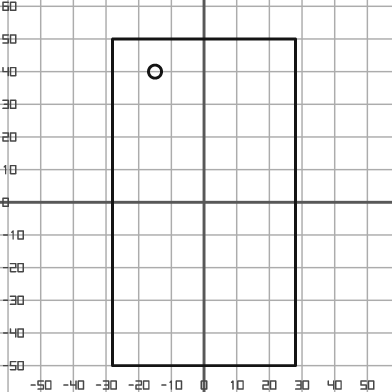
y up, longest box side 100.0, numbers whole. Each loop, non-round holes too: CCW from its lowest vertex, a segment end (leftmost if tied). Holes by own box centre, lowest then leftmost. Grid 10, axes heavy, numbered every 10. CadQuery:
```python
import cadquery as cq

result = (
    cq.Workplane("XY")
    .moveTo(-28.0, -50.0)
    .lineTo(28.0, -50.0)
    .lineTo(28.0, 50.0)
    .lineTo(-28.0, 50.0)
    .close()
    .moveTo(-15.0, 40.0)
    .circle(2.0)
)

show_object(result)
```